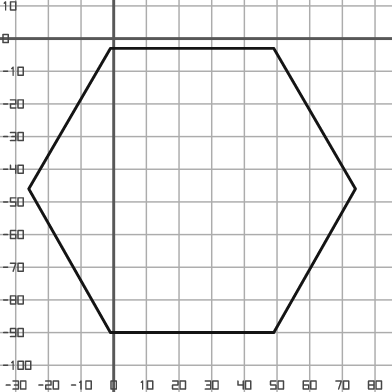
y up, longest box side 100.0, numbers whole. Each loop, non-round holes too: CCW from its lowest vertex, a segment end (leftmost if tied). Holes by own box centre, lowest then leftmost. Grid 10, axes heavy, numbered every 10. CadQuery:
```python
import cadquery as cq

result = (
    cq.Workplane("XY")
    .moveTo(-1.0, -90.0)
    .lineTo(49.0, -90.0)
    .lineTo(74.0, -46.0)
    .lineTo(49.0, -3.0)
    .lineTo(-1.0, -3.0)
    .lineTo(-26.0, -46.0)
    .close()
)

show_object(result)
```